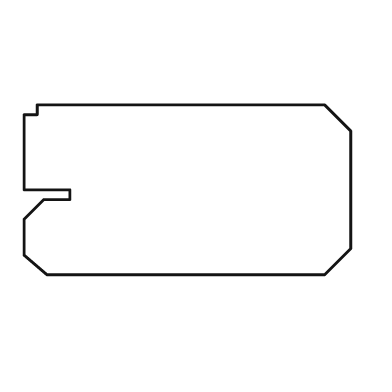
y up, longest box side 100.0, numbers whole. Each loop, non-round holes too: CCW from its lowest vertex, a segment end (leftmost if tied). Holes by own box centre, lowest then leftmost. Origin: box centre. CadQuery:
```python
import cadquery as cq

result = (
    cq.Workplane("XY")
    .moveTo(-43.0, -26.0)
    .lineTo(42.0, -26.0)
    .lineTo(50.0, -18.0)
    .lineTo(50.0, 18.0)
    .lineTo(42.0, 26.0)
    .lineTo(-46.0, 26.0)
    .lineTo(-46.0, 23.0)
    .lineTo(-50.0, 23.0)
    .lineTo(-50.0, 0.0)
    .lineTo(-36.0, 0.0)
    .lineTo(-36.0, -3.0)
    .lineTo(-44.0, -3.0)
    .lineTo(-50.0, -9.0)
    .lineTo(-50.0, -20.0)
    .close()
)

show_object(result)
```